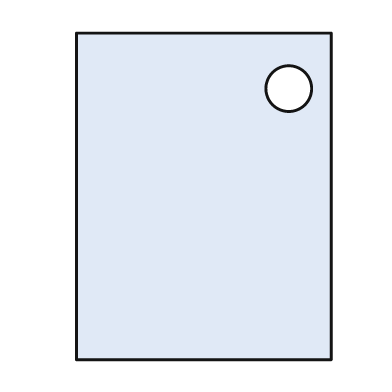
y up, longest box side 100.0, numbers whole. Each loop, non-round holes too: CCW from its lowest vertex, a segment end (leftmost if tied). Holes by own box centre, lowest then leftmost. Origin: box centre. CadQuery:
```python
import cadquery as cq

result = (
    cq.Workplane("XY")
    .moveTo(-39.0, -50.0)
    .lineTo(39.0, -50.0)
    .lineTo(39.0, 50.0)
    .lineTo(-39.0, 50.0)
    .close()
    .moveTo(26.0, 33.0)
    .circle(7.0)
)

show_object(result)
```